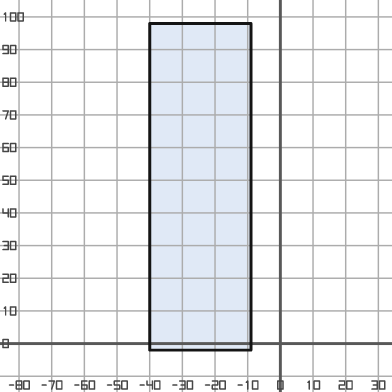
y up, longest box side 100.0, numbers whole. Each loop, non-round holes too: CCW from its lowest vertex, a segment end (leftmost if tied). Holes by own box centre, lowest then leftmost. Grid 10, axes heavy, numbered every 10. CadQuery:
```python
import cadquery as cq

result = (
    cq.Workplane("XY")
    .moveTo(-40.0, -2.0)
    .lineTo(-9.0, -2.0)
    .lineTo(-9.0, 98.0)
    .lineTo(-40.0, 98.0)
    .close()
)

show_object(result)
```